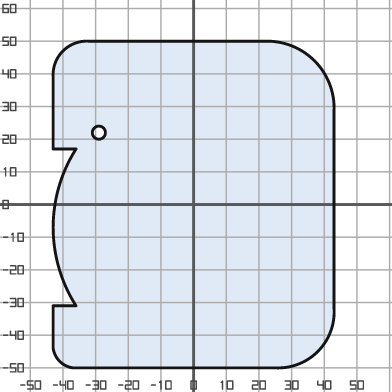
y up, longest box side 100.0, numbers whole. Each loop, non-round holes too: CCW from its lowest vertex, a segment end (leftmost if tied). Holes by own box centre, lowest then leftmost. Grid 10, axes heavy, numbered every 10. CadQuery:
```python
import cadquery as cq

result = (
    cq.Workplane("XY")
    .moveTo(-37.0, -50.0)
    .lineTo(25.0, -50.0)
    .threePointArc((38.0, -45.0), (43.0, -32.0))
    .lineTo(43.0, 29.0)
    .threePointArc((37.0, 44.0), (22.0, 50.0))
    .lineTo(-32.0, 50.0)
    .threePointArc((-40.0, 47.0), (-43.0, 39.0))
    .lineTo(-43.0, 17.0)
    .lineTo(-36.0, 17.0)
    .threePointArc((-43.0, -7.0), (-36.0, -31.0))
    .lineTo(-43.0, -31.0)
    .lineTo(-43.0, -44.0)
    .threePointArc((-41.0, -48.0), (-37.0, -50.0))
    .close()
    .moveTo(-29.0, 22.0)
    .circle(2.0)
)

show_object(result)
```